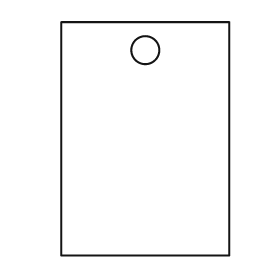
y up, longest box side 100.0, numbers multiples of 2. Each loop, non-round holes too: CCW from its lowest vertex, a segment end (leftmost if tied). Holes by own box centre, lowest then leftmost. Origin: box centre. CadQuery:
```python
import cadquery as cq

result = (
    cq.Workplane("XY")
    .moveTo(-36.0, -50.0)
    .lineTo(36.0, -50.0)
    .lineTo(36.0, 50.0)
    .lineTo(-36.0, 50.0)
    .close()
    .moveTo(0.0, 38.0)
    .circle(6.0)
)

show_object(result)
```